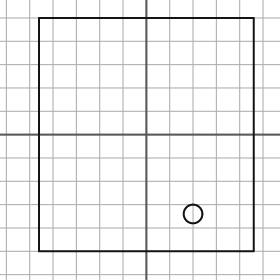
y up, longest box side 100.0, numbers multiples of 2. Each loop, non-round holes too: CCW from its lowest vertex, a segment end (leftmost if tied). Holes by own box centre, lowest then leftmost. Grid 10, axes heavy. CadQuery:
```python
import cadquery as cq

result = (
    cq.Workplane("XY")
    .moveTo(-46.0, -50.0)
    .lineTo(46.0, -50.0)
    .lineTo(46.0, 50.0)
    .lineTo(-46.0, 50.0)
    .close()
    .moveTo(20.0, -34.0)
    .circle(4.0)
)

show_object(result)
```